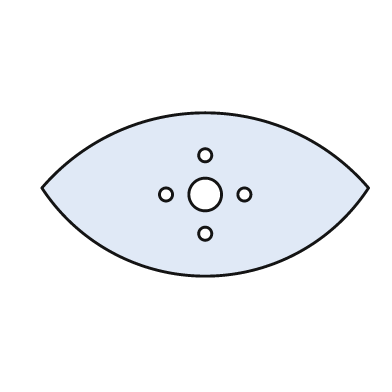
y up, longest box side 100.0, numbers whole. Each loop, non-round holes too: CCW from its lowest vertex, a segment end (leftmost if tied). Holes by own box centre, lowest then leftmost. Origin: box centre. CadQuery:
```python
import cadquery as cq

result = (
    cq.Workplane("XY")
    .moveTo(-50.0, 2.0)
    .threePointArc((0.0, -25.0), (50.0, 2.0))
    .threePointArc((0.0, 25.0), (-50.0, 2.0))
    .close()
    .moveTo(0.0, -12.0)
    .circle(2.0)
    .moveTo(-12.0, 0.0)
    .circle(2.0)
    .moveTo(0.0, 0.0)
    .circle(5.0)
    .moveTo(12.0, 0.0)
    .circle(2.0)
    .moveTo(0.0, 12.0)
    .circle(2.0)
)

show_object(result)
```